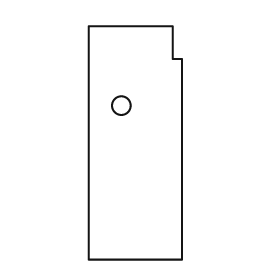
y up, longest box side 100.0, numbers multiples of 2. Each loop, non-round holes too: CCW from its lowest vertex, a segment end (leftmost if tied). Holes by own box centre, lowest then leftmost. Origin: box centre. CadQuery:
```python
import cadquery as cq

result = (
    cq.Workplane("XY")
    .moveTo(-20.0, -50.0)
    .lineTo(20.0, -50.0)
    .lineTo(20.0, 36.0)
    .lineTo(16.0, 36.0)
    .lineTo(16.0, 50.0)
    .lineTo(-20.0, 50.0)
    .close()
    .moveTo(-6.0, 16.0)
    .circle(4.0)
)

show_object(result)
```